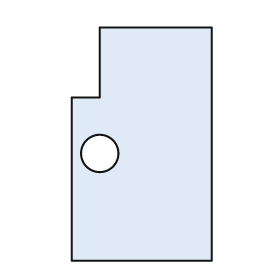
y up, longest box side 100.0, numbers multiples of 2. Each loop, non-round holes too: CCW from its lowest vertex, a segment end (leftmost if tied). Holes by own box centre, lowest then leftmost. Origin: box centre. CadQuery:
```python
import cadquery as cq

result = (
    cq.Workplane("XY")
    .moveTo(-30.0, -50.0)
    .lineTo(30.0, -50.0)
    .lineTo(30.0, 50.0)
    .lineTo(-18.0, 50.0)
    .lineTo(-18.0, 20.0)
    .lineTo(-30.0, 20.0)
    .close()
    .moveTo(-18.0, -4.0)
    .circle(8.0)
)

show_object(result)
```